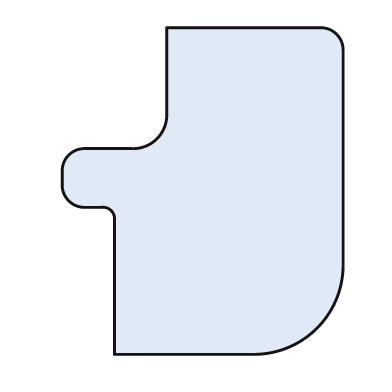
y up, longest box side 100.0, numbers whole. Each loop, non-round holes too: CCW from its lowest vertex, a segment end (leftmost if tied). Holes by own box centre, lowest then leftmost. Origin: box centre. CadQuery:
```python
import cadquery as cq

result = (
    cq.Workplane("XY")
    .moveTo(-27.0, -50.0)
    .lineTo(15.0, -50.0)
    .threePointArc((35.0, -42.0), (43.0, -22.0))
    .lineTo(43.0, 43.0)
    .threePointArc((41.0, 48.0), (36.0, 50.0))
    .lineTo(-11.0, 50.0)
    .lineTo(-11.0, 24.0)
    .threePointArc((-14.0, 16.0), (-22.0, 13.0))
    .lineTo(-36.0, 13.0)
    .threePointArc((-41.0, 11.0), (-43.0, 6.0))
    .lineTo(-43.0, 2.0)
    .threePointArc((-41.0, -3.0), (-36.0, -5.0))
    .lineTo(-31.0, -5.0)
    .threePointArc((-28.0, -6.0), (-27.0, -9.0))
    .close()
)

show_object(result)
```